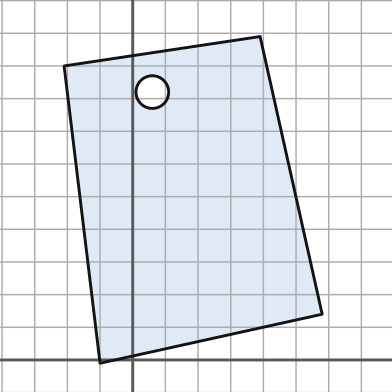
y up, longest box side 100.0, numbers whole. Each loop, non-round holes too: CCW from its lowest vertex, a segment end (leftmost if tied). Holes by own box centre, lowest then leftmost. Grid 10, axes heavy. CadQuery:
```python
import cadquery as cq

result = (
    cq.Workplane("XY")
    .moveTo(-10.0, -1.0)
    .lineTo(58.0, 14.0)
    .lineTo(39.0, 99.0)
    .lineTo(-21.0, 90.0)
    .close()
    .moveTo(6.0, 82.0)
    .circle(5.0)
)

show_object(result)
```